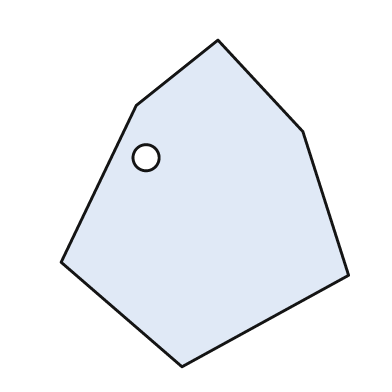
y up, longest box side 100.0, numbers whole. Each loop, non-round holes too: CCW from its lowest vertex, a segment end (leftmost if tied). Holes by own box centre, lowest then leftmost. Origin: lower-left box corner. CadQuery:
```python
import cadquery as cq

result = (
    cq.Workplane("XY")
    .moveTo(37.0, 0.0)
    .lineTo(88.0, 28.0)
    .lineTo(74.0, 72.0)
    .lineTo(48.0, 100.0)
    .lineTo(23.0, 80.0)
    .lineTo(0.0, 32.0)
    .close()
    .moveTo(26.0, 64.0)
    .circle(4.0)
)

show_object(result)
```